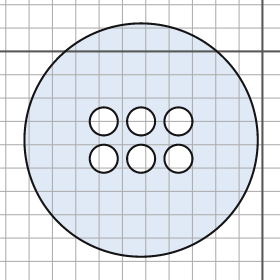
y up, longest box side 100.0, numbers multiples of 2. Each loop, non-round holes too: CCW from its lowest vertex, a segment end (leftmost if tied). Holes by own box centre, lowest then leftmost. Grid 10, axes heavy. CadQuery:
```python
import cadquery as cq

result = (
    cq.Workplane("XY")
    .moveTo(-52.0, -38.0)
    .circle(50.0)
    .moveTo(-68.0, -46.0)
    .circle(6.0)
    .moveTo(-52.0, -46.0)
    .circle(6.0)
    .moveTo(-36.0, -46.0)
    .circle(6.0)
    .moveTo(-68.0, -30.0)
    .circle(6.0)
    .moveTo(-52.0, -30.0)
    .circle(6.0)
    .moveTo(-36.0, -30.0)
    .circle(6.0)
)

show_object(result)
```